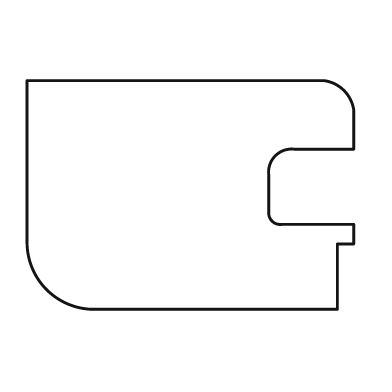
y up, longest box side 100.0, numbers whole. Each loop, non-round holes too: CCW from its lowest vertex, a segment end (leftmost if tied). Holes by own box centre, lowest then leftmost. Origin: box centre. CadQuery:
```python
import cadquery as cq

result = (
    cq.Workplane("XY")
    .moveTo(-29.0, -35.0)
    .lineTo(45.0, -35.0)
    .lineTo(45.0, -15.0)
    .lineTo(50.0, -15.0)
    .lineTo(50.0, -9.0)
    .lineTo(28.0, -9.0)
    .threePointArc((25.0, -8.0), (24.0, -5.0))
    .lineTo(24.0, 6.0)
    .threePointArc((26.0, 12.0), (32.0, 14.0))
    .lineTo(50.0, 14.0)
    .lineTo(50.0, 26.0)
    .threePointArc((47.0, 32.0), (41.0, 35.0))
    .lineTo(-50.0, 35.0)
    .lineTo(-50.0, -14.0)
    .threePointArc((-44.0, -29.0), (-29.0, -35.0))
    .close()
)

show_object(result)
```